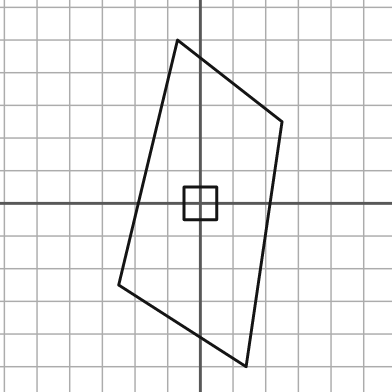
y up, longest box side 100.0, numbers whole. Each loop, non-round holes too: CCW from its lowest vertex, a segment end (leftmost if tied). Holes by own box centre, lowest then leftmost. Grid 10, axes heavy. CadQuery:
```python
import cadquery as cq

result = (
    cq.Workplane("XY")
    .moveTo(14.0, -50.0)
    .lineTo(25.0, 25.0)
    .lineTo(-7.0, 50.0)
    .lineTo(-25.0, -25.0)
    .close()
    .moveTo(-5.0, -5.0)
    .lineTo(5.0, -5.0)
    .lineTo(5.0, 5.0)
    .lineTo(-5.0, 5.0)
    .close()
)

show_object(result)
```